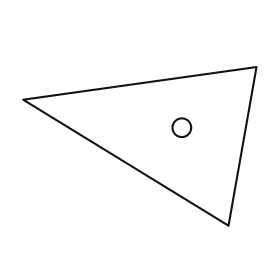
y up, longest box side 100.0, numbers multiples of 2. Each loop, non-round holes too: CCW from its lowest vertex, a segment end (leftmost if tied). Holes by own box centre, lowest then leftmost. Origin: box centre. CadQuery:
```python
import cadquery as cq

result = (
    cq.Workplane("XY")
    .moveTo(38.0, -34.0)
    .lineTo(50.0, 34.0)
    .lineTo(-50.0, 20.0)
    .close()
    .moveTo(18.0, 8.0)
    .circle(4.0)
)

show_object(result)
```